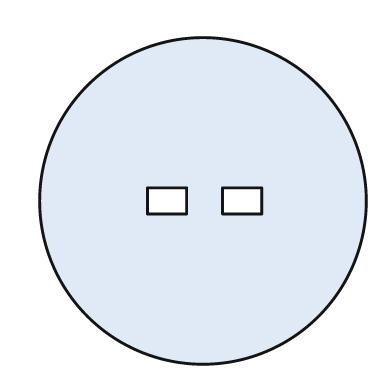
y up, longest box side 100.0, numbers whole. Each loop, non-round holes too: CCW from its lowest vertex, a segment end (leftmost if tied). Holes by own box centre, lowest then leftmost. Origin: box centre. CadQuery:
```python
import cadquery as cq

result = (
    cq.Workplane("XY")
    .moveTo(0.0, 0.0)
    .circle(50.0)
    .moveTo(-17.0, -4.0)
    .lineTo(-5.0, -4.0)
    .lineTo(-5.0, 4.0)
    .lineTo(-17.0, 4.0)
    .close()
    .moveTo(6.0, -4.0)
    .lineTo(18.0, -4.0)
    .lineTo(18.0, 4.0)
    .lineTo(6.0, 4.0)
    .close()
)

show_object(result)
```